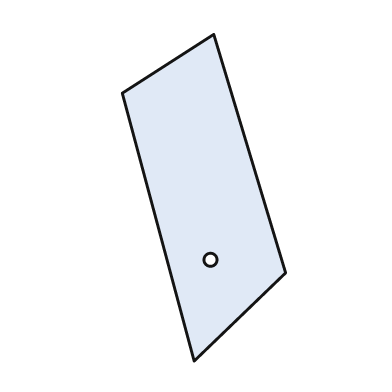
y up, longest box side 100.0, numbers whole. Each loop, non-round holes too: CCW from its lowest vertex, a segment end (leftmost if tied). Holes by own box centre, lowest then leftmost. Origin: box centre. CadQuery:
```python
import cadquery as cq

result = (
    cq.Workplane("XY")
    .moveTo(-3.0, -50.0)
    .lineTo(25.0, -23.0)
    .lineTo(3.0, 50.0)
    .lineTo(-25.0, 32.0)
    .close()
    .moveTo(2.0, -19.0)
    .circle(2.0)
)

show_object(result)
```